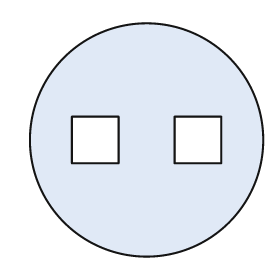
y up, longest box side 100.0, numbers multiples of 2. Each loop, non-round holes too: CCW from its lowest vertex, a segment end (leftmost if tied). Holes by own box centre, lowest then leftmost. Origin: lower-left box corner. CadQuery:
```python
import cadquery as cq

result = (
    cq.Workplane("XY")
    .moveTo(50.0, 50.0)
    .circle(50.0)
    .moveTo(18.0, 40.0)
    .lineTo(38.0, 40.0)
    .lineTo(38.0, 60.0)
    .lineTo(18.0, 60.0)
    .close()
    .moveTo(62.0, 40.0)
    .lineTo(82.0, 40.0)
    .lineTo(82.0, 60.0)
    .lineTo(62.0, 60.0)
    .close()
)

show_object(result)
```